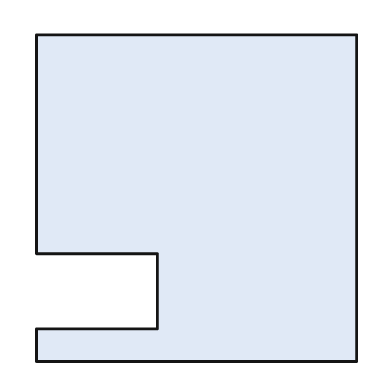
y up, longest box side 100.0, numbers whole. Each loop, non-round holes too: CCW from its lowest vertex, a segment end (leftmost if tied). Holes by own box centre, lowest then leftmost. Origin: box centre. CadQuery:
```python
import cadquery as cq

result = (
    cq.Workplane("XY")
    .moveTo(-49.0, -50.0)
    .lineTo(49.0, -50.0)
    .lineTo(49.0, 50.0)
    .lineTo(-49.0, 50.0)
    .lineTo(-49.0, -17.0)
    .lineTo(-12.0, -17.0)
    .lineTo(-12.0, -40.0)
    .lineTo(-49.0, -40.0)
    .close()
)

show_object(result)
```